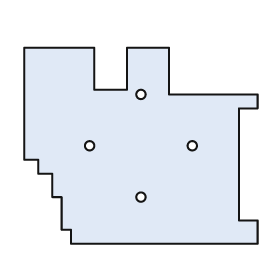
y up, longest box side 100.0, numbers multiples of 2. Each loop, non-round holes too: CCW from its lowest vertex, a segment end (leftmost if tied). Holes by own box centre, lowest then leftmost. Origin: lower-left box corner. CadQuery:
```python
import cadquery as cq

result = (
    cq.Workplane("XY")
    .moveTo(20.0, 0.0)
    .lineTo(100.0, 0.0)
    .lineTo(100.0, 10.0)
    .lineTo(92.0, 10.0)
    .lineTo(92.0, 58.0)
    .lineTo(100.0, 58.0)
    .lineTo(100.0, 64.0)
    .lineTo(62.0, 64.0)
    .lineTo(62.0, 84.0)
    .lineTo(44.0, 84.0)
    .lineTo(44.0, 66.0)
    .lineTo(30.0, 66.0)
    .lineTo(30.0, 84.0)
    .lineTo(0.0, 84.0)
    .lineTo(0.0, 36.0)
    .lineTo(6.0, 36.0)
    .lineTo(6.0, 30.0)
    .lineTo(12.0, 30.0)
    .lineTo(12.0, 20.0)
    .lineTo(16.0, 20.0)
    .lineTo(16.0, 6.0)
    .lineTo(20.0, 6.0)
    .close()
    .moveTo(50.0, 20.0)
    .circle(2.0)
    .moveTo(28.0, 42.0)
    .circle(2.0)
    .moveTo(72.0, 42.0)
    .circle(2.0)
    .moveTo(50.0, 64.0)
    .circle(2.0)
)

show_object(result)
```